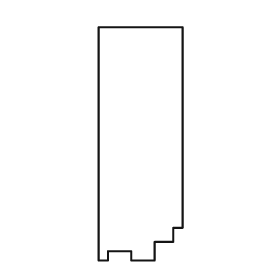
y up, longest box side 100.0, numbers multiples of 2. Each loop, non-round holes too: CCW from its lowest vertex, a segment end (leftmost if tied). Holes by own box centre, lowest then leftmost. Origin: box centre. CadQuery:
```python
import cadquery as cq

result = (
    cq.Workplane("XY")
    .moveTo(-18.0, -50.0)
    .lineTo(-14.0, -50.0)
    .lineTo(-14.0, -46.0)
    .lineTo(-4.0, -46.0)
    .lineTo(-4.0, -50.0)
    .lineTo(6.0, -50.0)
    .lineTo(6.0, -42.0)
    .lineTo(14.0, -42.0)
    .lineTo(14.0, -36.0)
    .lineTo(18.0, -36.0)
    .lineTo(18.0, 50.0)
    .lineTo(-18.0, 50.0)
    .close()
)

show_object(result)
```